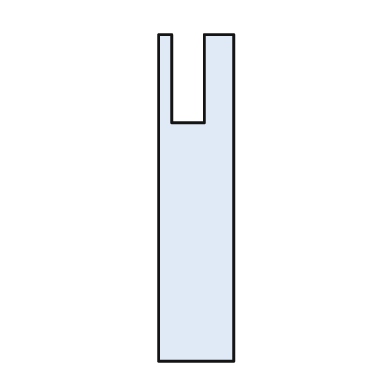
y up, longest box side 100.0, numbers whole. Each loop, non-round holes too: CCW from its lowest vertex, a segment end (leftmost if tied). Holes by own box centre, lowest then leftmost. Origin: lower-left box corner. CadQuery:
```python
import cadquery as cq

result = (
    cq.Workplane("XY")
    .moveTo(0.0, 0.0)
    .lineTo(23.0, 0.0)
    .lineTo(23.0, 100.0)
    .lineTo(14.0, 100.0)
    .lineTo(14.0, 73.0)
    .lineTo(4.0, 73.0)
    .lineTo(4.0, 100.0)
    .lineTo(0.0, 100.0)
    .close()
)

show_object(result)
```